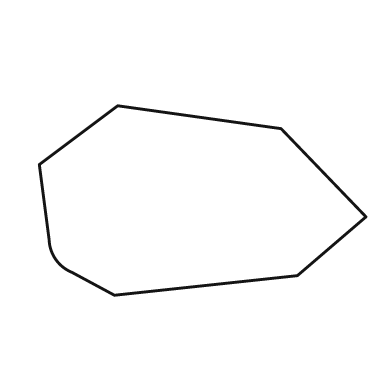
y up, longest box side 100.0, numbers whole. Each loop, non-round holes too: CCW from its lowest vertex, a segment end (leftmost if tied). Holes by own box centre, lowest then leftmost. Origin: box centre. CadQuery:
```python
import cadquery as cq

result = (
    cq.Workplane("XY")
    .moveTo(-27.0, -29.0)
    .lineTo(29.0, -23.0)
    .lineTo(50.0, -5.0)
    .lineTo(24.0, 22.0)
    .lineTo(-26.0, 29.0)
    .lineTo(-50.0, 11.0)
    .lineTo(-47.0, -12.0)
    .threePointArc((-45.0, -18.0), (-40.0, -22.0))
    .close()
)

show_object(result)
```